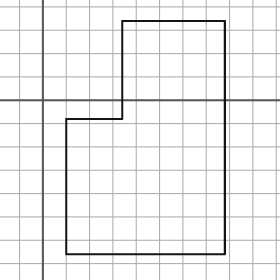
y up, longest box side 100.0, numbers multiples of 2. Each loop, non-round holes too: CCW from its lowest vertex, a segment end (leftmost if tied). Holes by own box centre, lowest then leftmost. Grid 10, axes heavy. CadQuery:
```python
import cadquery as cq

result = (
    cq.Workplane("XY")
    .moveTo(10.0, -66.0)
    .lineTo(78.0, -66.0)
    .lineTo(78.0, 34.0)
    .lineTo(34.0, 34.0)
    .lineTo(34.0, -8.0)
    .lineTo(10.0, -8.0)
    .close()
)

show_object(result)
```